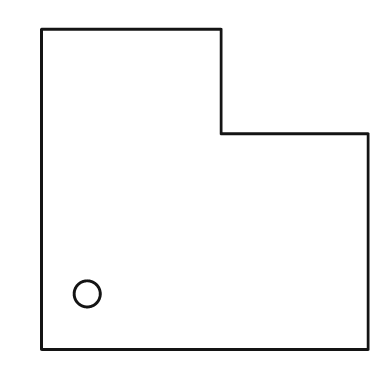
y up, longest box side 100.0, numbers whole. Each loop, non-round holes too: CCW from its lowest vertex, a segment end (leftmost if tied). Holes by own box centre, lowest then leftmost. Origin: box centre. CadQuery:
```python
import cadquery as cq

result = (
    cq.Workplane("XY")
    .moveTo(-50.0, -49.0)
    .lineTo(50.0, -49.0)
    .lineTo(50.0, 17.0)
    .lineTo(5.0, 17.0)
    .lineTo(5.0, 49.0)
    .lineTo(-50.0, 49.0)
    .close()
    .moveTo(-36.0, -32.0)
    .circle(4.0)
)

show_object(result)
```